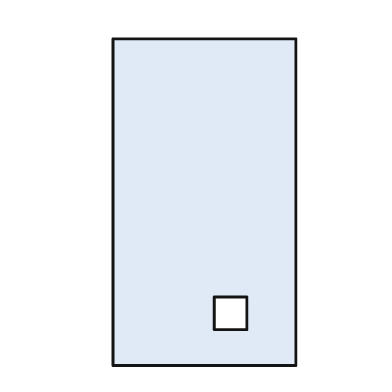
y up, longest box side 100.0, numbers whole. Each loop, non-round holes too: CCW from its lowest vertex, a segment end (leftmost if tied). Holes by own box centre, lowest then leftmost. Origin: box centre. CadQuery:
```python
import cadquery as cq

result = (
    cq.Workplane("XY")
    .moveTo(-28.0, -50.0)
    .lineTo(28.0, -50.0)
    .lineTo(28.0, 50.0)
    .lineTo(-28.0, 50.0)
    .close()
    .moveTo(3.0, -39.0)
    .lineTo(13.0, -39.0)
    .lineTo(13.0, -29.0)
    .lineTo(3.0, -29.0)
    .close()
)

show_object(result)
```